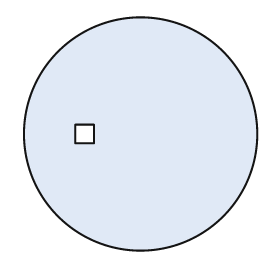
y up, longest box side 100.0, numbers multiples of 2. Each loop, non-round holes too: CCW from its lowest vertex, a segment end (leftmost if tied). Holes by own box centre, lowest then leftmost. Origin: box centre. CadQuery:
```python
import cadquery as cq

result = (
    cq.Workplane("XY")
    .moveTo(0.0, 0.0)
    .circle(50.0)
    .moveTo(-28.0, -4.0)
    .lineTo(-20.0, -4.0)
    .lineTo(-20.0, 4.0)
    .lineTo(-28.0, 4.0)
    .close()
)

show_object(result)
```